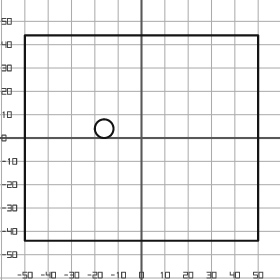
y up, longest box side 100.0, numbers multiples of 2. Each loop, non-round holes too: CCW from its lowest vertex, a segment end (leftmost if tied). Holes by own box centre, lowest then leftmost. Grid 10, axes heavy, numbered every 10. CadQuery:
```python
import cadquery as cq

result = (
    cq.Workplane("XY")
    .moveTo(-50.0, -44.0)
    .lineTo(50.0, -44.0)
    .lineTo(50.0, 44.0)
    .lineTo(-50.0, 44.0)
    .close()
    .moveTo(-16.0, 4.0)
    .circle(4.0)
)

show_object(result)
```